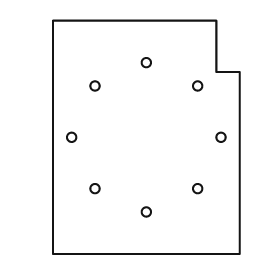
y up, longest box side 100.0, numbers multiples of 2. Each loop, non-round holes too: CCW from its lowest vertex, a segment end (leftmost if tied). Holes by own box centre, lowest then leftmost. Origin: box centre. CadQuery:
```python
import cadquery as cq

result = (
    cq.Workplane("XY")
    .moveTo(-40.0, -50.0)
    .lineTo(40.0, -50.0)
    .lineTo(40.0, 28.0)
    .lineTo(30.0, 28.0)
    .lineTo(30.0, 50.0)
    .lineTo(-40.0, 50.0)
    .close()
    .moveTo(0.0, -32.0)
    .circle(2.0)
    .moveTo(-22.0, -22.0)
    .circle(2.0)
    .moveTo(22.0, -22.0)
    .circle(2.0)
    .moveTo(-32.0, 0.0)
    .circle(2.0)
    .moveTo(32.0, 0.0)
    .circle(2.0)
    .moveTo(-22.0, 22.0)
    .circle(2.0)
    .moveTo(22.0, 22.0)
    .circle(2.0)
    .moveTo(0.0, 32.0)
    .circle(2.0)
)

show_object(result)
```